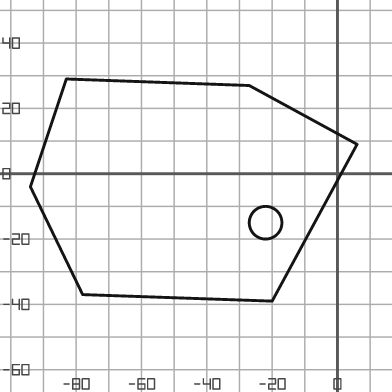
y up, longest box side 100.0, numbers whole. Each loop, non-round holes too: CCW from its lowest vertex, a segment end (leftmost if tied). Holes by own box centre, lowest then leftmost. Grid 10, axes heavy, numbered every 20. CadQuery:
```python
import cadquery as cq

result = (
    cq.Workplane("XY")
    .moveTo(-20.0, -39.0)
    .lineTo(6.0, 9.0)
    .lineTo(-27.0, 27.0)
    .lineTo(-83.0, 29.0)
    .lineTo(-94.0, -4.0)
    .lineTo(-78.0, -37.0)
    .close()
    .moveTo(-22.0, -15.0)
    .circle(5.0)
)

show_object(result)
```